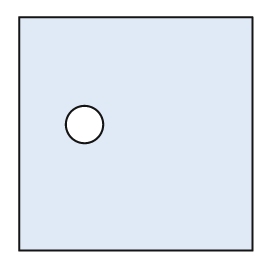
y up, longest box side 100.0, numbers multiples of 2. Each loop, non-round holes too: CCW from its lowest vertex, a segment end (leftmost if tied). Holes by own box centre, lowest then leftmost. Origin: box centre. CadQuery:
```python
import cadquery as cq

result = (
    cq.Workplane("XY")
    .moveTo(-50.0, -50.0)
    .lineTo(50.0, -50.0)
    .lineTo(50.0, 50.0)
    .lineTo(-50.0, 50.0)
    .close()
    .moveTo(-22.0, 4.0)
    .circle(8.0)
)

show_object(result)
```